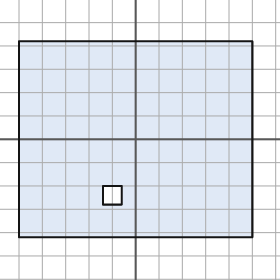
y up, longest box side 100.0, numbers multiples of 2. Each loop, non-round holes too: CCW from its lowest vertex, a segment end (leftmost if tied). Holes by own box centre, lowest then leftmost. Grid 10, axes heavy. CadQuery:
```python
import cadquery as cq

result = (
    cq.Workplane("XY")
    .moveTo(-50.0, -42.0)
    .lineTo(50.0, -42.0)
    .lineTo(50.0, 42.0)
    .lineTo(-50.0, 42.0)
    .close()
    .moveTo(-14.0, -28.0)
    .lineTo(-6.0, -28.0)
    .lineTo(-6.0, -20.0)
    .lineTo(-14.0, -20.0)
    .close()
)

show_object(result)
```